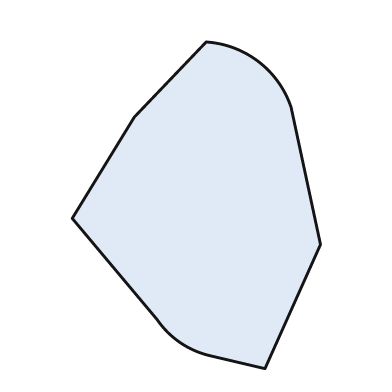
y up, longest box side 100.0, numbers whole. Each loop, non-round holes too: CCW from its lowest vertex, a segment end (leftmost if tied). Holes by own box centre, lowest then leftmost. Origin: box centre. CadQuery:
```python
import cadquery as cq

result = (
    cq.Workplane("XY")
    .moveTo(21.0, -50.0)
    .lineTo(38.0, -12.0)
    .lineTo(29.0, 30.0)
    .threePointArc((19.0, 44.0), (3.0, 50.0))
    .lineTo(-19.0, 27.0)
    .lineTo(-38.0, -4.0)
    .lineTo(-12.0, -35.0)
    .threePointArc((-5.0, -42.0), (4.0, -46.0))
    .close()
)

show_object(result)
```